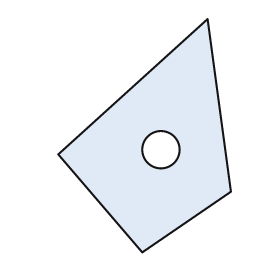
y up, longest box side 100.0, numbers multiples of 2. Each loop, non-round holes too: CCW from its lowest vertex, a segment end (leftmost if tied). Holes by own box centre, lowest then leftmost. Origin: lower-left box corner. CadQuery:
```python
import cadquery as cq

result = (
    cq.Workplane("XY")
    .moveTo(36.0, 0.0)
    .lineTo(74.0, 26.0)
    .lineTo(64.0, 100.0)
    .lineTo(0.0, 42.0)
    .close()
    .moveTo(44.0, 44.0)
    .circle(8.0)
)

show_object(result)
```